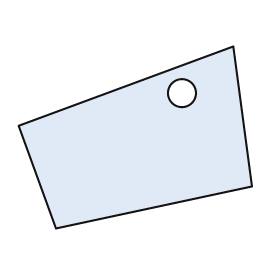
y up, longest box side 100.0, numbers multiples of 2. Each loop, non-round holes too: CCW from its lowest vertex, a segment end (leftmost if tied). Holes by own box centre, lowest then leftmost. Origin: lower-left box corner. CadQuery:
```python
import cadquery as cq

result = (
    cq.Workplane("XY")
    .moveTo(16.0, 0.0)
    .lineTo(100.0, 18.0)
    .lineTo(92.0, 78.0)
    .lineTo(0.0, 44.0)
    .close()
    .moveTo(70.0, 58.0)
    .circle(6.0)
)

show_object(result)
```